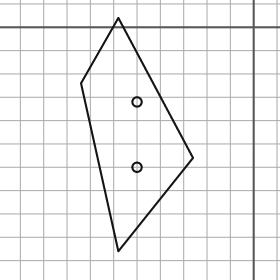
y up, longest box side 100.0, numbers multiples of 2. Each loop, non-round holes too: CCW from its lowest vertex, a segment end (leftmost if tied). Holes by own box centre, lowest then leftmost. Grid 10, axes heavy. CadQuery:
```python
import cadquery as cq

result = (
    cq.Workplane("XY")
    .moveTo(-58.0, -96.0)
    .lineTo(-26.0, -56.0)
    .lineTo(-58.0, 4.0)
    .lineTo(-74.0, -24.0)
    .close()
    .moveTo(-50.0, -60.0)
    .circle(2.0)
    .moveTo(-50.0, -32.0)
    .circle(2.0)
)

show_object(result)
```